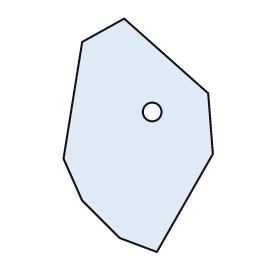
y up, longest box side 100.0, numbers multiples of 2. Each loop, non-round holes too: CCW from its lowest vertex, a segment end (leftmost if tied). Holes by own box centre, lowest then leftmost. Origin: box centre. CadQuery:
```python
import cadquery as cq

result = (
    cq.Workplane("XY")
    .moveTo(8.0, -50.0)
    .lineTo(32.0, -8.0)
    .lineTo(30.0, 18.0)
    .lineTo(-6.0, 50.0)
    .lineTo(-24.0, 40.0)
    .lineTo(-32.0, -10.0)
    .lineTo(-24.0, -28.0)
    .lineTo(-8.0, -44.0)
    .close()
    .moveTo(6.0, 10.0)
    .circle(4.0)
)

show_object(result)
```